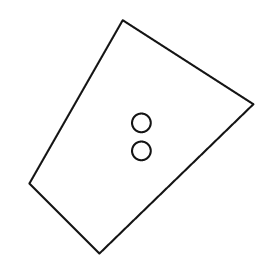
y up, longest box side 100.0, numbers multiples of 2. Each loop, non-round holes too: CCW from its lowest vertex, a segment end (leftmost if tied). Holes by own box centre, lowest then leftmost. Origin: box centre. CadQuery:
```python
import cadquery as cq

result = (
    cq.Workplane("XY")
    .moveTo(-18.0, -50.0)
    .lineTo(48.0, 14.0)
    .lineTo(-8.0, 50.0)
    .lineTo(-48.0, -20.0)
    .close()
    .moveTo(0.0, -6.0)
    .circle(4.0)
    .moveTo(0.0, 6.0)
    .circle(4.0)
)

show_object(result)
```